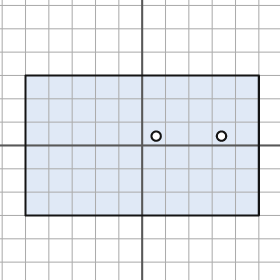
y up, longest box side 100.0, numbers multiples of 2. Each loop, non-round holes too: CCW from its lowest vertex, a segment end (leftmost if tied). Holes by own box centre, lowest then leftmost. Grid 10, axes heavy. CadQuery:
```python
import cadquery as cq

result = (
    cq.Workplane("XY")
    .moveTo(-50.0, -30.0)
    .lineTo(50.0, -30.0)
    .lineTo(50.0, 30.0)
    .lineTo(-50.0, 30.0)
    .close()
    .moveTo(6.0, 4.0)
    .circle(2.0)
    .moveTo(34.0, 4.0)
    .circle(2.0)
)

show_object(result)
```